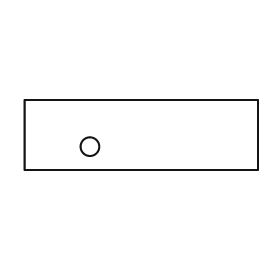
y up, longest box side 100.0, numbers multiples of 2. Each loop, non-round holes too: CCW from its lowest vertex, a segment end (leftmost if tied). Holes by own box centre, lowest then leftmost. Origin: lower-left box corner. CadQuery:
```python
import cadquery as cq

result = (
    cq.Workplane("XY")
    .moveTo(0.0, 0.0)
    .lineTo(100.0, 0.0)
    .lineTo(100.0, 30.0)
    .lineTo(0.0, 30.0)
    .close()
    .moveTo(28.0, 10.0)
    .circle(4.0)
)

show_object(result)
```